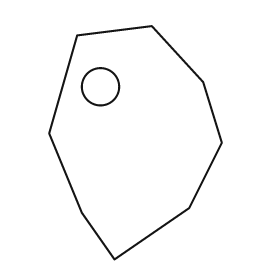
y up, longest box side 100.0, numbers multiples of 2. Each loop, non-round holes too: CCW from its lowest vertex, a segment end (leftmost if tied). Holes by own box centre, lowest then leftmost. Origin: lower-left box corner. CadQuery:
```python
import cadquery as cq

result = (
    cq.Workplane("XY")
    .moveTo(28.0, 0.0)
    .lineTo(60.0, 22.0)
    .lineTo(74.0, 50.0)
    .lineTo(66.0, 76.0)
    .lineTo(44.0, 100.0)
    .lineTo(12.0, 96.0)
    .lineTo(0.0, 54.0)
    .lineTo(14.0, 20.0)
    .close()
    .moveTo(22.0, 74.0)
    .circle(8.0)
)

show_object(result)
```